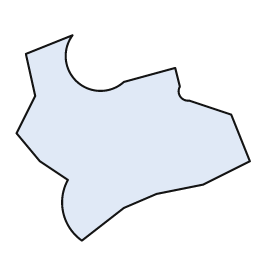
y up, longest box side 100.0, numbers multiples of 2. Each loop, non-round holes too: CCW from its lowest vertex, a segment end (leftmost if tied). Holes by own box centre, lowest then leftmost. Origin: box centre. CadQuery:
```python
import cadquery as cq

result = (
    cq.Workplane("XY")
    .moveTo(-22.0, -44.0)
    .lineTo(-4.0, -30.0)
    .lineTo(10.0, -24.0)
    .lineTo(30.0, -20.0)
    .lineTo(50.0, -10.0)
    .lineTo(42.0, 10.0)
    .lineTo(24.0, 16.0)
    .threePointArc((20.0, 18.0), (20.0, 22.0))
    .lineTo(18.0, 30.0)
    .lineTo(-4.0, 24.0)
    .threePointArc((-24.0, 24.0), (-26.0, 44.0))
    .lineTo(-46.0, 36.0)
    .lineTo(-42.0, 18.0)
    .lineTo(-50.0, 2.0)
    .lineTo(-40.0, -10.0)
    .lineTo(-28.0, -18.0)
    .threePointArc((-30.0, -32.0), (-22.0, -44.0))
    .close()
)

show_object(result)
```